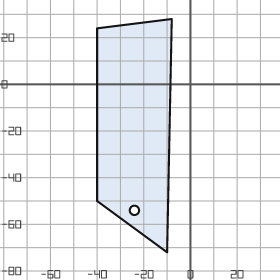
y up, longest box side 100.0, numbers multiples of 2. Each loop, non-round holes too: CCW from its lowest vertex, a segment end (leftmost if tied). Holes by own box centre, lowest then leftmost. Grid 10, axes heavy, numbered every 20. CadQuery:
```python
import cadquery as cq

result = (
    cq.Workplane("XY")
    .moveTo(-10.0, -72.0)
    .lineTo(-8.0, 28.0)
    .lineTo(-40.0, 24.0)
    .lineTo(-40.0, -50.0)
    .close()
    .moveTo(-24.0, -54.0)
    .circle(2.0)
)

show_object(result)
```